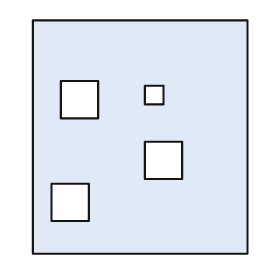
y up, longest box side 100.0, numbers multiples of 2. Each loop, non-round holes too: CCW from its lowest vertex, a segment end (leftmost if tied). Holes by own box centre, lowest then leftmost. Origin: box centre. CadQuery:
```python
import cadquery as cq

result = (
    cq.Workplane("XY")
    .moveTo(-46.0, -50.0)
    .lineTo(46.0, -50.0)
    .lineTo(46.0, 50.0)
    .lineTo(-46.0, 50.0)
    .close()
    .moveTo(-38.0, -36.0)
    .lineTo(-22.0, -36.0)
    .lineTo(-22.0, -20.0)
    .lineTo(-38.0, -20.0)
    .close()
    .moveTo(2.0, -18.0)
    .lineTo(18.0, -18.0)
    .lineTo(18.0, -2.0)
    .lineTo(2.0, -2.0)
    .close()
    .moveTo(-34.0, 8.0)
    .lineTo(-18.0, 8.0)
    .lineTo(-18.0, 24.0)
    .lineTo(-34.0, 24.0)
    .close()
    .moveTo(2.0, 14.0)
    .lineTo(10.0, 14.0)
    .lineTo(10.0, 22.0)
    .lineTo(2.0, 22.0)
    .close()
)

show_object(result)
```